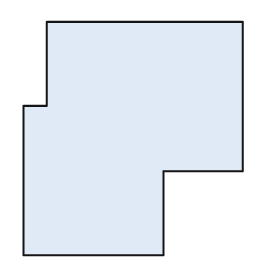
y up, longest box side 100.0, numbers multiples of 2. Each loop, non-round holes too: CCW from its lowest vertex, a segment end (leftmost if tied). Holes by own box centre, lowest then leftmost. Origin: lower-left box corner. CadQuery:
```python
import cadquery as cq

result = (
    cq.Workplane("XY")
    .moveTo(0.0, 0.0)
    .lineTo(60.0, 0.0)
    .lineTo(60.0, 36.0)
    .lineTo(94.0, 36.0)
    .lineTo(94.0, 100.0)
    .lineTo(10.0, 100.0)
    .lineTo(10.0, 64.0)
    .lineTo(0.0, 64.0)
    .close()
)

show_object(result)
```